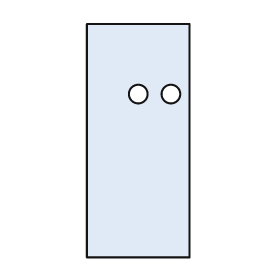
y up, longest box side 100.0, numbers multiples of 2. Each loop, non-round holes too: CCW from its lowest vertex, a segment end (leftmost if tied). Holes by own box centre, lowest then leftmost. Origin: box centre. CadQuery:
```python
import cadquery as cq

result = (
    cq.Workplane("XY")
    .moveTo(-22.0, -50.0)
    .lineTo(22.0, -50.0)
    .lineTo(22.0, 50.0)
    .lineTo(-22.0, 50.0)
    .close()
    .moveTo(0.0, 20.0)
    .circle(4.0)
    .moveTo(14.0, 20.0)
    .circle(4.0)
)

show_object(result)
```